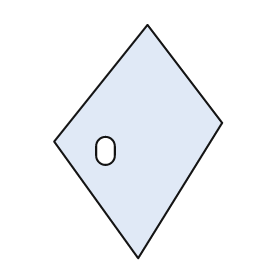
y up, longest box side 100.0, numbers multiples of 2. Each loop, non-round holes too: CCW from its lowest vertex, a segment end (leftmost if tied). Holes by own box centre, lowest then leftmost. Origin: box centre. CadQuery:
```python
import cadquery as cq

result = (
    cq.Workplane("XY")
    .moveTo(0.0, -50.0)
    .lineTo(36.0, 8.0)
    .lineTo(4.0, 50.0)
    .lineTo(-36.0, 0.0)
    .close()
    .moveTo(-18.0, -6.0)
    .threePointArc((-14.0, -10.0), (-10.0, -6.0))
    .lineTo(-10.0, -2.0)
    .threePointArc((-14.0, 2.0), (-18.0, -2.0))
    .close()
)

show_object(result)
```